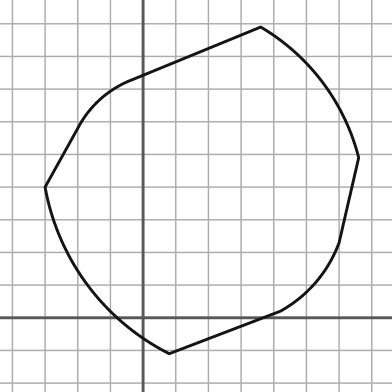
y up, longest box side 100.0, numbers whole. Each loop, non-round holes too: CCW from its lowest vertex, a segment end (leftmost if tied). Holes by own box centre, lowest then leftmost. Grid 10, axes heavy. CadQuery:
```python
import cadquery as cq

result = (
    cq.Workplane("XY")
    .moveTo(8.0, -11.0)
    .lineTo(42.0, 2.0)
    .threePointArc((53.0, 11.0), (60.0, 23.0))
    .lineTo(66.0, 49.0)
    .threePointArc((55.0, 72.0), (36.0, 89.0))
    .lineTo(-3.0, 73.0)
    .threePointArc((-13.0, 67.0), (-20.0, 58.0))
    .lineTo(-30.0, 40.0)
    .threePointArc((-17.0, 10.0), (8.0, -11.0))
    .close()
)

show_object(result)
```